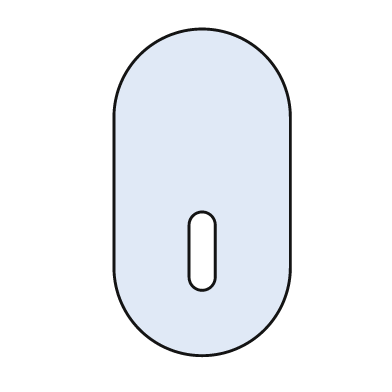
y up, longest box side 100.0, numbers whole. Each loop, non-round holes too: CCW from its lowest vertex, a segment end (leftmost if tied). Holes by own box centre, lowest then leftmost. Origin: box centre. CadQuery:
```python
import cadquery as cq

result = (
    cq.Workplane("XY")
    .moveTo(-27.0, -23.0)
    .threePointArc((0.0, -50.0), (27.0, -23.0))
    .lineTo(27.0, 23.0)
    .threePointArc((0.0, 50.0), (-27.0, 23.0))
    .close()
    .moveTo(-4.0, -26.0)
    .threePointArc((0.0, -30.0), (4.0, -26.0))
    .lineTo(4.0, -10.0)
    .threePointArc((0.0, -6.0), (-4.0, -10.0))
    .close()
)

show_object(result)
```